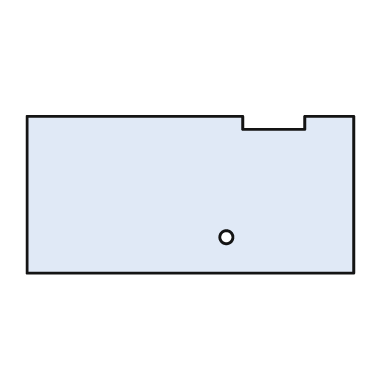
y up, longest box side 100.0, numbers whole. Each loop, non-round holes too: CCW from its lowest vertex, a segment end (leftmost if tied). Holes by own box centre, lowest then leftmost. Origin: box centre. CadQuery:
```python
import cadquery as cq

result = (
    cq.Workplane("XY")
    .moveTo(-50.0, -24.0)
    .lineTo(50.0, -24.0)
    .lineTo(50.0, 24.0)
    .lineTo(35.0, 24.0)
    .lineTo(35.0, 20.0)
    .lineTo(16.0, 20.0)
    .lineTo(16.0, 24.0)
    .lineTo(-50.0, 24.0)
    .close()
    .moveTo(11.0, -13.0)
    .circle(2.0)
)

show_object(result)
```